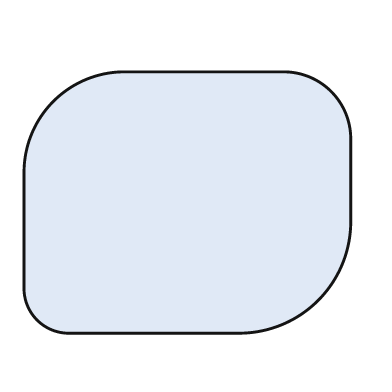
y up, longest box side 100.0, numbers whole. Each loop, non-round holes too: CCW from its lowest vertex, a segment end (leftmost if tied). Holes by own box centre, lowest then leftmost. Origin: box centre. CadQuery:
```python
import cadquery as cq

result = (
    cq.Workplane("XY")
    .moveTo(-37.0, -40.0)
    .lineTo(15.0, -40.0)
    .threePointArc((40.0, -30.0), (50.0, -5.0))
    .lineTo(50.0, 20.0)
    .threePointArc((44.0, 34.0), (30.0, 40.0))
    .lineTo(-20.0, 40.0)
    .threePointArc((-41.0, 31.0), (-50.0, 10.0))
    .lineTo(-50.0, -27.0)
    .threePointArc((-46.0, -36.0), (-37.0, -40.0))
    .close()
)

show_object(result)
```